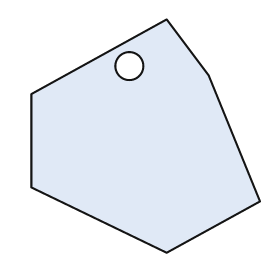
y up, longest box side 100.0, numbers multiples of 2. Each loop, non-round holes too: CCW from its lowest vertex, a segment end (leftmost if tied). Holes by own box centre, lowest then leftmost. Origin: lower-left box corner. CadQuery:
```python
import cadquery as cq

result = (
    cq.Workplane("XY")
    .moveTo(58.0, 0.0)
    .lineTo(98.0, 22.0)
    .lineTo(76.0, 76.0)
    .lineTo(58.0, 100.0)
    .lineTo(0.0, 68.0)
    .lineTo(0.0, 28.0)
    .close()
    .moveTo(42.0, 80.0)
    .circle(6.0)
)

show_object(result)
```